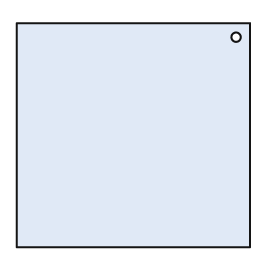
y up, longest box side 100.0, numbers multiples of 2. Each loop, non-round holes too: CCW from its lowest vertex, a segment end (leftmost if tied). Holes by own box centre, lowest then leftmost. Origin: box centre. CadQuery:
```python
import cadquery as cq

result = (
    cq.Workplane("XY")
    .moveTo(-50.0, -48.0)
    .lineTo(50.0, -48.0)
    .lineTo(50.0, 48.0)
    .lineTo(-50.0, 48.0)
    .close()
    .moveTo(44.0, 42.0)
    .circle(2.0)
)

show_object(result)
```